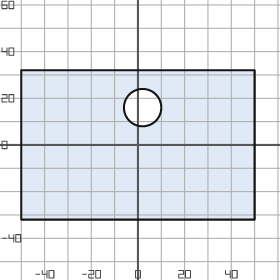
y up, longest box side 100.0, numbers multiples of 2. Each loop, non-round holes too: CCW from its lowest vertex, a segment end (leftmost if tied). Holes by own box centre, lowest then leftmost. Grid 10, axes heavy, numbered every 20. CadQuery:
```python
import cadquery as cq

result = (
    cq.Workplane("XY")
    .moveTo(-50.0, -32.0)
    .lineTo(50.0, -32.0)
    .lineTo(50.0, 32.0)
    .lineTo(-50.0, 32.0)
    .close()
    .moveTo(2.0, 16.0)
    .circle(8.0)
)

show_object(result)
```